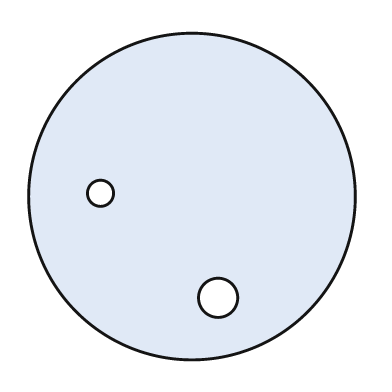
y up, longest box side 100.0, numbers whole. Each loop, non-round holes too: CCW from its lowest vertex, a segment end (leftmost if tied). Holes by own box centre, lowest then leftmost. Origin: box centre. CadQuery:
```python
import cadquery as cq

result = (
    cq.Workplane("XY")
    .moveTo(0.0, 0.0)
    .circle(50.0)
    .moveTo(8.0, -31.0)
    .circle(6.0)
    .moveTo(-28.0, 1.0)
    .circle(4.0)
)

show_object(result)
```